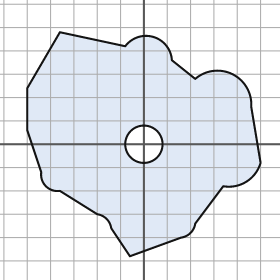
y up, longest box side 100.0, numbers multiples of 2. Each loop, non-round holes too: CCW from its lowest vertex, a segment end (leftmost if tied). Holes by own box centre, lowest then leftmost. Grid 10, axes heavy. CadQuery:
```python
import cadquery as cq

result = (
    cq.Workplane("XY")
    .moveTo(-6.0, -48.0)
    .lineTo(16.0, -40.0)
    .threePointArc((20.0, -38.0), (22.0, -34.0))
    .lineTo(34.0, -18.0)
    .threePointArc((44.0, -16.0), (50.0, -8.0))
    .lineTo(46.0, 16.0)
    .threePointArc((38.0, 30.0), (22.0, 28.0))
    .lineTo(12.0, 36.0)
    .threePointArc((4.0, 46.0), (-8.0, 42.0))
    .lineTo(-36.0, 48.0)
    .lineTo(-50.0, 24.0)
    .lineTo(-50.0, 6.0)
    .lineTo(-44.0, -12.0)
    .threePointArc((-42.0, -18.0), (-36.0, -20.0))
    .lineTo(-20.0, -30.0)
    .threePointArc((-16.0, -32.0), (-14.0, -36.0))
    .close()
    .moveTo(0.0, 0.0)
    .circle(8.0)
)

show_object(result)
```